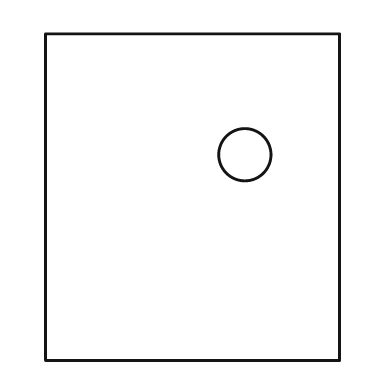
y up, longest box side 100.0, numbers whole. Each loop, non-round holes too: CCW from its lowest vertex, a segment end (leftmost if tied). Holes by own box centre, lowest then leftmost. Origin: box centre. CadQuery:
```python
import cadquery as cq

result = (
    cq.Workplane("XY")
    .moveTo(-45.0, -50.0)
    .lineTo(45.0, -50.0)
    .lineTo(45.0, 50.0)
    .lineTo(-45.0, 50.0)
    .close()
    .moveTo(16.0, 13.0)
    .circle(8.0)
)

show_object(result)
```